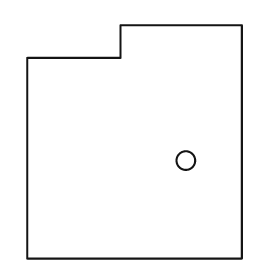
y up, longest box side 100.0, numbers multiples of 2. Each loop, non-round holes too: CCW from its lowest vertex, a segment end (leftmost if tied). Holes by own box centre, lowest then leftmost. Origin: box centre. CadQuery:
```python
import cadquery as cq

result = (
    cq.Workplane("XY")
    .moveTo(-46.0, -50.0)
    .lineTo(46.0, -50.0)
    .lineTo(46.0, 50.0)
    .lineTo(-6.0, 50.0)
    .lineTo(-6.0, 36.0)
    .lineTo(-46.0, 36.0)
    .close()
    .moveTo(22.0, -8.0)
    .circle(4.0)
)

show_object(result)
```